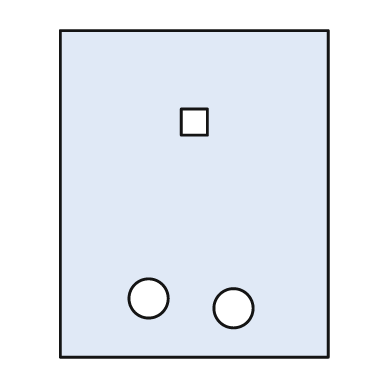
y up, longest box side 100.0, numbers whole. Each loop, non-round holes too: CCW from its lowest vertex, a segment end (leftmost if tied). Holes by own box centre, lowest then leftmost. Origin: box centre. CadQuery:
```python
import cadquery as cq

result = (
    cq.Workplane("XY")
    .moveTo(-41.0, -50.0)
    .lineTo(41.0, -50.0)
    .lineTo(41.0, 50.0)
    .lineTo(-41.0, 50.0)
    .close()
    .moveTo(12.0, -35.0)
    .circle(6.0)
    .moveTo(-14.0, -32.0)
    .circle(6.0)
    .moveTo(-4.0, 18.0)
    .lineTo(4.0, 18.0)
    .lineTo(4.0, 26.0)
    .lineTo(-4.0, 26.0)
    .close()
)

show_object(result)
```